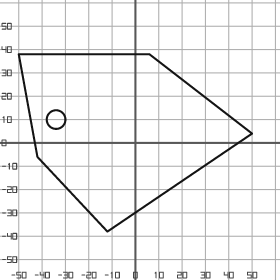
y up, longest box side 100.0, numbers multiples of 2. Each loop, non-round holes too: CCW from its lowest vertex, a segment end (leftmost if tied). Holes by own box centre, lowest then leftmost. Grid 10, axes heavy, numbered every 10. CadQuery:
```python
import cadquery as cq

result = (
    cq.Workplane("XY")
    .moveTo(-12.0, -38.0)
    .lineTo(50.0, 4.0)
    .lineTo(6.0, 38.0)
    .lineTo(-50.0, 38.0)
    .lineTo(-42.0, -6.0)
    .close()
    .moveTo(-34.0, 10.0)
    .circle(4.0)
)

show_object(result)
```